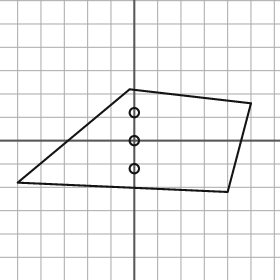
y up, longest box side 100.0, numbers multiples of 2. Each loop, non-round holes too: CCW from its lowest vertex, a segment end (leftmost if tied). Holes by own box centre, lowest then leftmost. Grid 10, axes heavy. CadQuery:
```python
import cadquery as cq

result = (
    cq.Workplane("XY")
    .moveTo(40.0, -22.0)
    .lineTo(50.0, 16.0)
    .lineTo(-2.0, 22.0)
    .lineTo(-50.0, -18.0)
    .close()
    .moveTo(0.0, -12.0)
    .circle(2.0)
    .moveTo(0.0, 0.0)
    .circle(2.0)
    .moveTo(0.0, 12.0)
    .circle(2.0)
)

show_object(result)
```